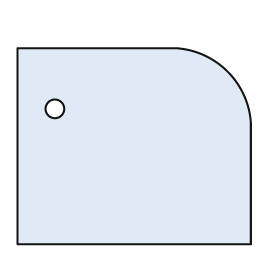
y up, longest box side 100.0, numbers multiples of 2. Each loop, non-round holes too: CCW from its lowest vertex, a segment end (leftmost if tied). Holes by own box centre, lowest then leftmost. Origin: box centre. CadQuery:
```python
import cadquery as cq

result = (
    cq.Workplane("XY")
    .moveTo(-50.0, -42.0)
    .lineTo(50.0, -42.0)
    .lineTo(50.0, 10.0)
    .threePointArc((40.0, 32.0), (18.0, 42.0))
    .lineTo(-50.0, 42.0)
    .close()
    .moveTo(-34.0, 16.0)
    .circle(4.0)
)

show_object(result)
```